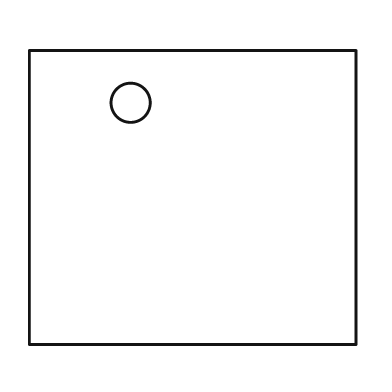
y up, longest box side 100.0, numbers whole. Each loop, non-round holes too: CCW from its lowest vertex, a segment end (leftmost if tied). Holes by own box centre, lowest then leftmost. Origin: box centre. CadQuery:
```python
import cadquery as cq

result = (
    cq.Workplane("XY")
    .moveTo(-50.0, -45.0)
    .lineTo(50.0, -45.0)
    .lineTo(50.0, 45.0)
    .lineTo(-50.0, 45.0)
    .close()
    .moveTo(-19.0, 29.0)
    .circle(6.0)
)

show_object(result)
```